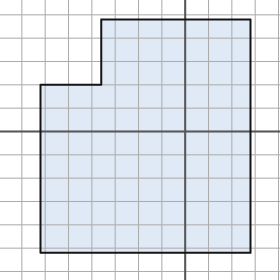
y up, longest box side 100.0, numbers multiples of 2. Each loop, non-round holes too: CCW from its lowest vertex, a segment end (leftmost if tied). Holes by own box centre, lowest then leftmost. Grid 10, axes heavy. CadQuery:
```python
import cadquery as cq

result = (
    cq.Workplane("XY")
    .moveTo(-62.0, -52.0)
    .lineTo(28.0, -52.0)
    .lineTo(28.0, 48.0)
    .lineTo(-36.0, 48.0)
    .lineTo(-36.0, 20.0)
    .lineTo(-62.0, 20.0)
    .close()
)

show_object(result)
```